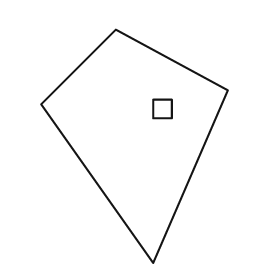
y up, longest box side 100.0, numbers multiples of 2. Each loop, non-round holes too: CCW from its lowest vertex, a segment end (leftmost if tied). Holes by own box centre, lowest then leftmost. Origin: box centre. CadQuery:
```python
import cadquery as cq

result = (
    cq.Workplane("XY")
    .moveTo(8.0, -50.0)
    .lineTo(40.0, 24.0)
    .lineTo(-8.0, 50.0)
    .lineTo(-40.0, 18.0)
    .close()
    .moveTo(8.0, 12.0)
    .lineTo(16.0, 12.0)
    .lineTo(16.0, 20.0)
    .lineTo(8.0, 20.0)
    .close()
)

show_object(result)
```